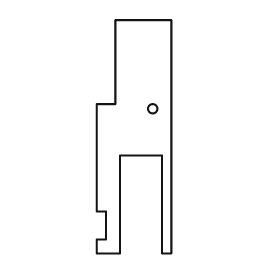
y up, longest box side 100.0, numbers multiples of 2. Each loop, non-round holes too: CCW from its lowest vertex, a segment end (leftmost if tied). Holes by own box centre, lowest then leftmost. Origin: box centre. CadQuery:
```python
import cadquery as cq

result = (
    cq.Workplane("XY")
    .moveTo(-16.0, -50.0)
    .lineTo(-6.0, -50.0)
    .lineTo(-6.0, -8.0)
    .lineTo(12.0, -8.0)
    .lineTo(12.0, -50.0)
    .lineTo(16.0, -50.0)
    .lineTo(16.0, 50.0)
    .lineTo(-8.0, 50.0)
    .lineTo(-8.0, 14.0)
    .lineTo(-16.0, 14.0)
    .lineTo(-16.0, -32.0)
    .lineTo(-12.0, -32.0)
    .lineTo(-12.0, -44.0)
    .lineTo(-16.0, -44.0)
    .close()
    .moveTo(8.0, 12.0)
    .circle(2.0)
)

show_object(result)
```